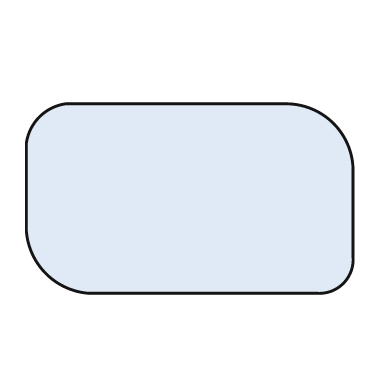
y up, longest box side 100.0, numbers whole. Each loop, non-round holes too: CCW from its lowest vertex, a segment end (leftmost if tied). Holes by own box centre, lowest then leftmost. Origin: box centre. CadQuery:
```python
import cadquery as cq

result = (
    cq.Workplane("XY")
    .moveTo(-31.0, -29.0)
    .lineTo(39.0, -29.0)
    .threePointArc((47.0, -26.0), (50.0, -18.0))
    .lineTo(50.0, 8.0)
    .threePointArc((44.0, 23.0), (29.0, 29.0))
    .lineTo(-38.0, 29.0)
    .threePointArc((-46.0, 25.0), (-50.0, 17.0))
    .lineTo(-50.0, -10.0)
    .threePointArc((-44.0, -23.0), (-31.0, -29.0))
    .close()
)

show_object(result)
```